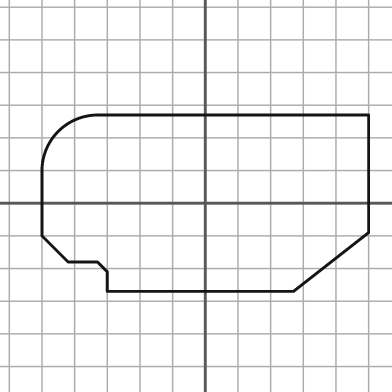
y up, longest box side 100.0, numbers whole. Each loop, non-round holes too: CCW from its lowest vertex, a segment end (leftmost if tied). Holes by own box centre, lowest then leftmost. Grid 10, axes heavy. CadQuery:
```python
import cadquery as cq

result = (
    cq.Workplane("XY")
    .moveTo(-30.0, -27.0)
    .lineTo(27.0, -27.0)
    .lineTo(50.0, -9.0)
    .lineTo(50.0, 27.0)
    .lineTo(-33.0, 27.0)
    .threePointArc((-45.0, 22.0), (-50.0, 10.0))
    .lineTo(-50.0, -10.0)
    .lineTo(-42.0, -18.0)
    .lineTo(-33.0, -18.0)
    .lineTo(-30.0, -21.0)
    .close()
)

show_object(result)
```